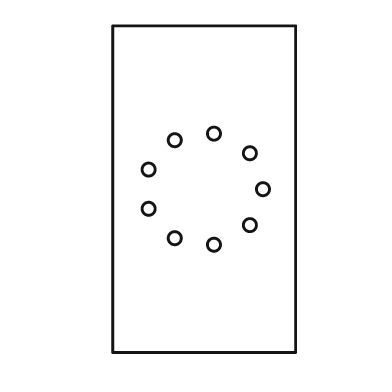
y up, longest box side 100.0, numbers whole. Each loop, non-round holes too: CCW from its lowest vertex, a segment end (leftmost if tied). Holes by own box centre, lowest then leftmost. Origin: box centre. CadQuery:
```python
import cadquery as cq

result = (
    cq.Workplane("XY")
    .moveTo(-28.0, -50.0)
    .lineTo(28.0, -50.0)
    .lineTo(28.0, 50.0)
    .lineTo(-28.0, 50.0)
    .close()
    .moveTo(3.0, -17.0)
    .circle(2.0)
    .moveTo(-9.0, -15.0)
    .circle(2.0)
    .moveTo(14.0, -11.0)
    .circle(2.0)
    .moveTo(-17.0, -6.0)
    .circle(2.0)
    .moveTo(18.0, 0.0)
    .circle(2.0)
    .moveTo(-17.0, 6.0)
    .circle(2.0)
    .moveTo(14.0, 11.0)
    .circle(2.0)
    .moveTo(-9.0, 15.0)
    .circle(2.0)
    .moveTo(3.0, 17.0)
    .circle(2.0)
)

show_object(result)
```